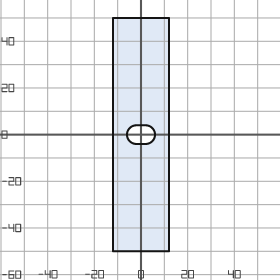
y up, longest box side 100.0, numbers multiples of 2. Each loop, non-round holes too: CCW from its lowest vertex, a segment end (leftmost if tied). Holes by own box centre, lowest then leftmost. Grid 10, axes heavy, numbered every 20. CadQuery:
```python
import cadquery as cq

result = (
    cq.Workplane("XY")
    .moveTo(-12.0, -50.0)
    .lineTo(12.0, -50.0)
    .lineTo(12.0, 50.0)
    .lineTo(-12.0, 50.0)
    .close()
    .moveTo(-2.0, -4.0)
    .lineTo(2.0, -4.0)
    .threePointArc((6.0, 0.0), (2.0, 4.0))
    .lineTo(-2.0, 4.0)
    .threePointArc((-6.0, 0.0), (-2.0, -4.0))
    .close()
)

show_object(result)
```